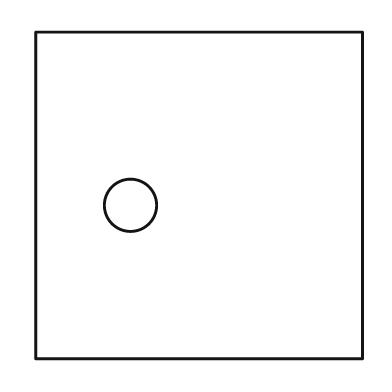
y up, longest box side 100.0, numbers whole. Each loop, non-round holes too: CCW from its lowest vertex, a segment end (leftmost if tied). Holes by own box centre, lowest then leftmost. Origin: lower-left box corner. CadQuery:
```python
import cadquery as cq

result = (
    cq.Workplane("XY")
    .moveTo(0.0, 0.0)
    .lineTo(100.0, 0.0)
    .lineTo(100.0, 100.0)
    .lineTo(0.0, 100.0)
    .close()
    .moveTo(29.0, 47.0)
    .circle(8.0)
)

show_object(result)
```